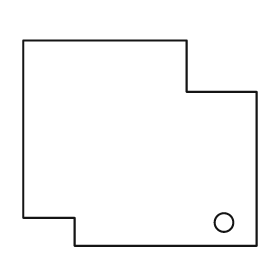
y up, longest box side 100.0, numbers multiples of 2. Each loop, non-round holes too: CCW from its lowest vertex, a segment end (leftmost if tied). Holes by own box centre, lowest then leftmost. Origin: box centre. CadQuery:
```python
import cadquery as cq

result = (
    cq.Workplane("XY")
    .moveTo(-28.0, -44.0)
    .lineTo(50.0, -44.0)
    .lineTo(50.0, 22.0)
    .lineTo(20.0, 22.0)
    .lineTo(20.0, 44.0)
    .lineTo(-50.0, 44.0)
    .lineTo(-50.0, -32.0)
    .lineTo(-28.0, -32.0)
    .close()
    .moveTo(36.0, -34.0)
    .circle(4.0)
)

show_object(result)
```